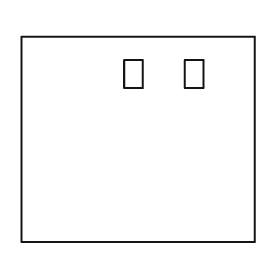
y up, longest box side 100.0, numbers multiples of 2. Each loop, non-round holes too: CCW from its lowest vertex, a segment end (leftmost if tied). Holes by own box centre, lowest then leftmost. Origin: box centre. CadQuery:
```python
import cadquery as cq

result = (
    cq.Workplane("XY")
    .moveTo(-50.0, -44.0)
    .lineTo(50.0, -44.0)
    .lineTo(50.0, 44.0)
    .lineTo(-50.0, 44.0)
    .close()
    .moveTo(-6.0, 22.0)
    .lineTo(2.0, 22.0)
    .lineTo(2.0, 34.0)
    .lineTo(-6.0, 34.0)
    .close()
    .moveTo(20.0, 22.0)
    .lineTo(28.0, 22.0)
    .lineTo(28.0, 34.0)
    .lineTo(20.0, 34.0)
    .close()
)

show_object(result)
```